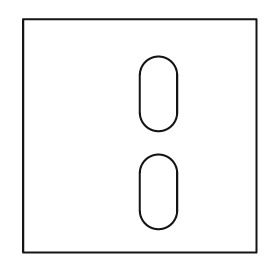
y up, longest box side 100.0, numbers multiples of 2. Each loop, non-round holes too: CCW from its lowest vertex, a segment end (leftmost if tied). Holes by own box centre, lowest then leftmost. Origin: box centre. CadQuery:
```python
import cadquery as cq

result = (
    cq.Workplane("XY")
    .moveTo(-50.0, -50.0)
    .lineTo(50.0, -50.0)
    .lineTo(50.0, 50.0)
    .lineTo(-50.0, 50.0)
    .close()
    .moveTo(0.0, -32.0)
    .threePointArc((8.0, -40.0), (16.0, -32.0))
    .lineTo(16.0, -16.0)
    .threePointArc((8.0, -8.0), (0.0, -16.0))
    .close()
    .moveTo(0.0, 10.0)
    .threePointArc((8.0, 2.0), (16.0, 10.0))
    .lineTo(16.0, 26.0)
    .threePointArc((8.0, 34.0), (0.0, 26.0))
    .close()
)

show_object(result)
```